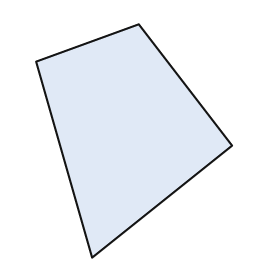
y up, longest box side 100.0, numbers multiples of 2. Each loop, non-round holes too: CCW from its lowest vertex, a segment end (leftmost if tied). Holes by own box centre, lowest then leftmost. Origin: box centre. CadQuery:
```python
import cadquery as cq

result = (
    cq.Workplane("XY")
    .moveTo(-18.0, -50.0)
    .lineTo(42.0, -2.0)
    .lineTo(2.0, 50.0)
    .lineTo(-42.0, 34.0)
    .close()
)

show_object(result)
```